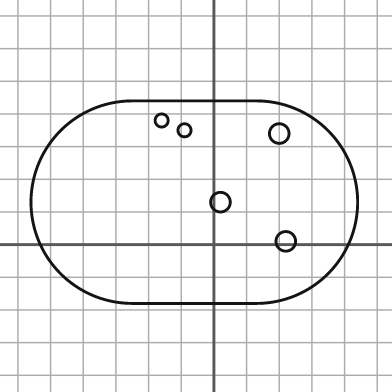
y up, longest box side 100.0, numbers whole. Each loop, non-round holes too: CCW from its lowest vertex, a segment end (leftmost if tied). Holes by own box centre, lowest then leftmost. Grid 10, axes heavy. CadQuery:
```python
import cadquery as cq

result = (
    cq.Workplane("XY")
    .moveTo(-25.0, -18.0)
    .lineTo(13.0, -18.0)
    .threePointArc((44.0, 13.0), (13.0, 44.0))
    .lineTo(-25.0, 44.0)
    .threePointArc((-56.0, 13.0), (-25.0, -18.0))
    .close()
    .moveTo(22.0, 1.0)
    .circle(3.0)
    .moveTo(2.0, 13.0)
    .circle(3.0)
    .moveTo(20.0, 34.0)
    .circle(3.0)
    .moveTo(-9.0, 35.0)
    .circle(2.0)
    .moveTo(-16.0, 38.0)
    .circle(2.0)
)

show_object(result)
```